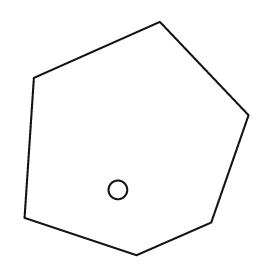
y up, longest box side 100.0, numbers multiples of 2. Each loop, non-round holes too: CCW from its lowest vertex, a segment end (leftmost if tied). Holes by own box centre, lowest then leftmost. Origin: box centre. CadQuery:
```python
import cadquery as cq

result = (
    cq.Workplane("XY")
    .moveTo(0.0, -50.0)
    .lineTo(32.0, -36.0)
    .lineTo(48.0, 10.0)
    .lineTo(10.0, 50.0)
    .lineTo(-44.0, 26.0)
    .lineTo(-48.0, -34.0)
    .close()
    .moveTo(-8.0, -22.0)
    .circle(4.0)
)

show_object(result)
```